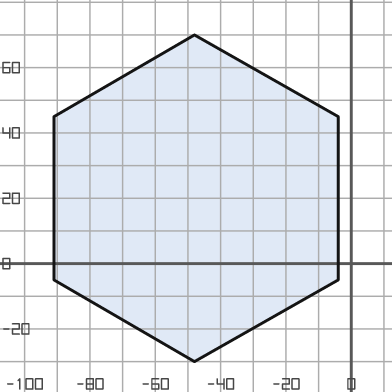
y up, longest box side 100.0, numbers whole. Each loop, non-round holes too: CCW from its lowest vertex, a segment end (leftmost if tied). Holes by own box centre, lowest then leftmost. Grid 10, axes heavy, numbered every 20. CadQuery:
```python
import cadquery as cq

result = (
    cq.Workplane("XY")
    .moveTo(-48.0, -30.0)
    .lineTo(-4.0, -5.0)
    .lineTo(-4.0, 45.0)
    .lineTo(-48.0, 70.0)
    .lineTo(-91.0, 45.0)
    .lineTo(-91.0, -5.0)
    .close()
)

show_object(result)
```